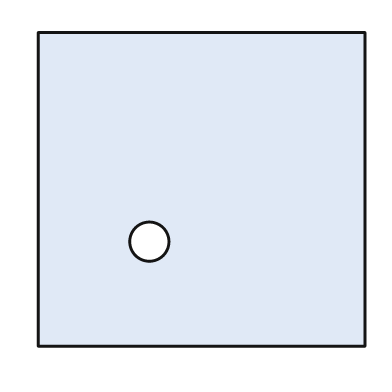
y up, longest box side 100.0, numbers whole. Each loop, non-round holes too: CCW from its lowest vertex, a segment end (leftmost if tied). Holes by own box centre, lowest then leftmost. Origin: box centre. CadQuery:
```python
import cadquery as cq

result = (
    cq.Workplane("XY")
    .moveTo(-50.0, -48.0)
    .lineTo(50.0, -48.0)
    .lineTo(50.0, 48.0)
    .lineTo(-50.0, 48.0)
    .close()
    .moveTo(-16.0, -16.0)
    .circle(6.0)
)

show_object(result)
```